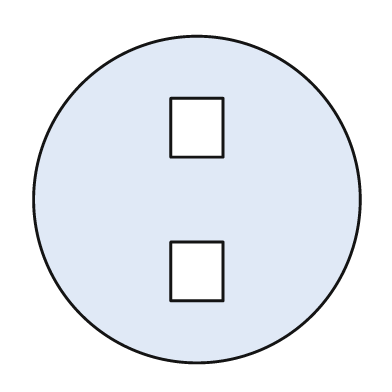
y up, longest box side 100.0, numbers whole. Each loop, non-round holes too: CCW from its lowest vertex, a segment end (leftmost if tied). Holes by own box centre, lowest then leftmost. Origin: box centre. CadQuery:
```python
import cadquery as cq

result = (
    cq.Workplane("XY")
    .moveTo(0.0, 0.0)
    .circle(50.0)
    .moveTo(-8.0, -31.0)
    .lineTo(8.0, -31.0)
    .lineTo(8.0, -13.0)
    .lineTo(-8.0, -13.0)
    .close()
    .moveTo(-8.0, 13.0)
    .lineTo(8.0, 13.0)
    .lineTo(8.0, 31.0)
    .lineTo(-8.0, 31.0)
    .close()
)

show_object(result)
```